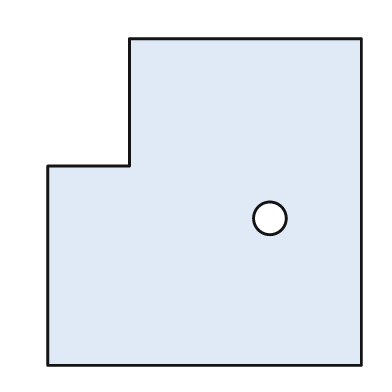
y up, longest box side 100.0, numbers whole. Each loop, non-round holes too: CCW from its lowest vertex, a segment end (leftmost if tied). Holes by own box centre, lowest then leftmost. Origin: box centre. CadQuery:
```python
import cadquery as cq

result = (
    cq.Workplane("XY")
    .moveTo(-48.0, -50.0)
    .lineTo(48.0, -50.0)
    .lineTo(48.0, 50.0)
    .lineTo(-23.0, 50.0)
    .lineTo(-23.0, 11.0)
    .lineTo(-48.0, 11.0)
    .close()
    .moveTo(20.0, -5.0)
    .circle(5.0)
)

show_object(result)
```